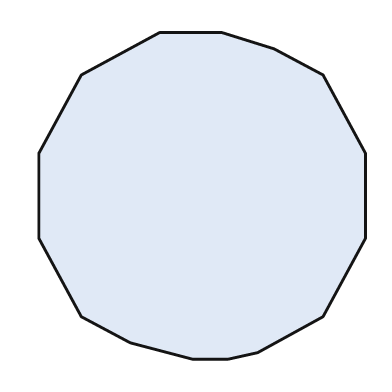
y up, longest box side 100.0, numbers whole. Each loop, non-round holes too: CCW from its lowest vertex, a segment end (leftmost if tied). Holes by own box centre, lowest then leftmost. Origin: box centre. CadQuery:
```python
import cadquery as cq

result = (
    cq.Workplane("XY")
    .moveTo(-3.0, -50.0)
    .lineTo(8.0, -50.0)
    .lineTo(17.0, -48.0)
    .lineTo(37.0, -37.0)
    .lineTo(50.0, -13.0)
    .lineTo(50.0, 13.0)
    .lineTo(37.0, 37.0)
    .lineTo(22.0, 45.0)
    .lineTo(6.0, 50.0)
    .lineTo(-13.0, 50.0)
    .lineTo(-37.0, 37.0)
    .lineTo(-50.0, 13.0)
    .lineTo(-50.0, -13.0)
    .lineTo(-37.0, -37.0)
    .lineTo(-22.0, -45.0)
    .close()
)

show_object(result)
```